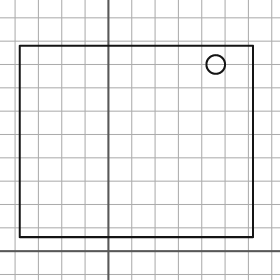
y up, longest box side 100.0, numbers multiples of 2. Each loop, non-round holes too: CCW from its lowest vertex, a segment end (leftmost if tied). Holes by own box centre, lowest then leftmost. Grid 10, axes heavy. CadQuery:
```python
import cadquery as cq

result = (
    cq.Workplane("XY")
    .moveTo(-38.0, 6.0)
    .lineTo(62.0, 6.0)
    .lineTo(62.0, 88.0)
    .lineTo(-38.0, 88.0)
    .close()
    .moveTo(46.0, 80.0)
    .circle(4.0)
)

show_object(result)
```